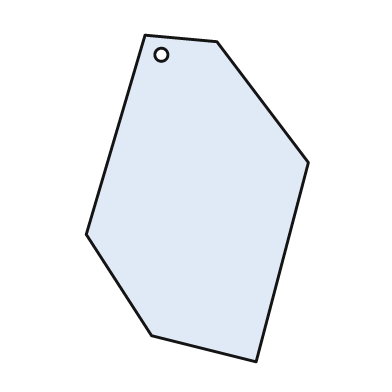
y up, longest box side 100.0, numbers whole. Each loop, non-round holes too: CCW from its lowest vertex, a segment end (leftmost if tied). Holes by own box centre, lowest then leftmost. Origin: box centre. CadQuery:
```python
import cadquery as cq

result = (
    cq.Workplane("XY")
    .moveTo(18.0, -50.0)
    .lineTo(34.0, 11.0)
    .lineTo(6.0, 48.0)
    .lineTo(-16.0, 50.0)
    .lineTo(-34.0, -11.0)
    .lineTo(-14.0, -42.0)
    .close()
    .moveTo(-11.0, 44.0)
    .circle(2.0)
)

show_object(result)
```